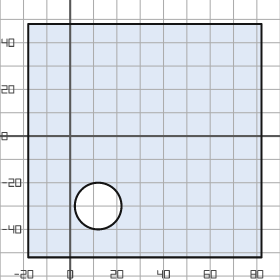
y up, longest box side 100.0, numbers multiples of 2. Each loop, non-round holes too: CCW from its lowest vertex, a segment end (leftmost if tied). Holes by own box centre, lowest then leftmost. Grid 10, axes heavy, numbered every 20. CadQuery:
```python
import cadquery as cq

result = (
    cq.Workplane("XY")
    .moveTo(-18.0, -52.0)
    .lineTo(82.0, -52.0)
    .lineTo(82.0, 48.0)
    .lineTo(-18.0, 48.0)
    .close()
    .moveTo(12.0, -30.0)
    .circle(10.0)
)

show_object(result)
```